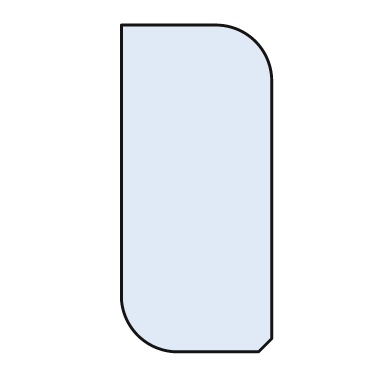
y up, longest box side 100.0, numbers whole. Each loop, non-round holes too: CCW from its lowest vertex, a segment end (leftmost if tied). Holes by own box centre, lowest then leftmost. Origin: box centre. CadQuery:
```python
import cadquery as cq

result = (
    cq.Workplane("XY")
    .moveTo(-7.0, -50.0)
    .lineTo(19.0, -50.0)
    .lineTo(23.0, -46.0)
    .lineTo(23.0, 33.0)
    .threePointArc((18.0, 45.0), (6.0, 50.0))
    .lineTo(-23.0, 50.0)
    .lineTo(-23.0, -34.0)
    .threePointArc((-18.0, -45.0), (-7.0, -50.0))
    .close()
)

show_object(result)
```